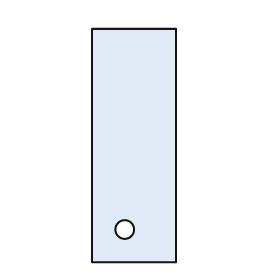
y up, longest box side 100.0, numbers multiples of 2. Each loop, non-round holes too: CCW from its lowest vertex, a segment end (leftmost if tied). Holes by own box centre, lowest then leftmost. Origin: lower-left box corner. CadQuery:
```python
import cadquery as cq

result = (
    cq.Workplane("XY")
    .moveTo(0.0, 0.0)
    .lineTo(36.0, 0.0)
    .lineTo(36.0, 100.0)
    .lineTo(0.0, 100.0)
    .close()
    .moveTo(14.0, 14.0)
    .circle(4.0)
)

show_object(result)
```